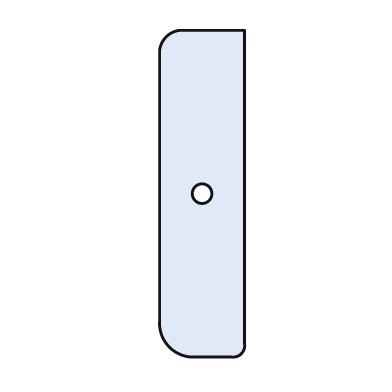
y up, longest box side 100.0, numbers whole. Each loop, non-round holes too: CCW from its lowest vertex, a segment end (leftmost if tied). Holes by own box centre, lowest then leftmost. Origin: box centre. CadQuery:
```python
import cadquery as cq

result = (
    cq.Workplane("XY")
    .moveTo(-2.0, -50.0)
    .lineTo(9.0, -50.0)
    .threePointArc((12.0, -49.0), (13.0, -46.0))
    .lineTo(13.0, 50.0)
    .lineTo(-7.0, 50.0)
    .threePointArc((-11.0, 48.0), (-13.0, 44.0))
    .lineTo(-13.0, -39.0)
    .threePointArc((-10.0, -47.0), (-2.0, -50.0))
    .close()
    .moveTo(0.0, 0.0)
    .circle(3.0)
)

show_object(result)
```